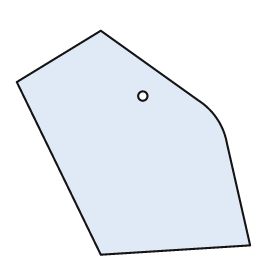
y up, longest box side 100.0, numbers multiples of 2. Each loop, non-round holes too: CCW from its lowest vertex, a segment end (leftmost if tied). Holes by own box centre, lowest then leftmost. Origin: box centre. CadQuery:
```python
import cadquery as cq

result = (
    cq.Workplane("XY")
    .moveTo(-14.0, -48.0)
    .lineTo(50.0, -44.0)
    .lineTo(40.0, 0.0)
    .threePointArc((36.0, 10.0), (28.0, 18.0))
    .lineTo(-14.0, 48.0)
    .lineTo(-50.0, 26.0)
    .close()
    .moveTo(4.0, 20.0)
    .circle(2.0)
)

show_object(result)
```